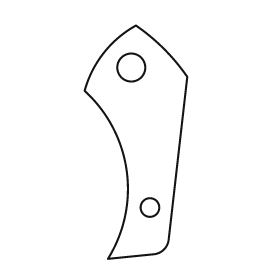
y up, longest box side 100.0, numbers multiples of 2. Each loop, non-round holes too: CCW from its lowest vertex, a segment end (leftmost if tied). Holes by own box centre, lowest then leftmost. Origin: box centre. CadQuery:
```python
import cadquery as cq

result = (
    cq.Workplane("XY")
    .moveTo(-12.0, -50.0)
    .lineTo(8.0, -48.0)
    .threePointArc((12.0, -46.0), (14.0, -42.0))
    .lineTo(22.0, 28.0)
    .threePointArc((12.0, 40.0), (0.0, 50.0))
    .threePointArc((-14.0, 38.0), (-22.0, 22.0))
    .threePointArc((-4.0, -12.0), (-12.0, -50.0))
    .close()
    .moveTo(6.0, -28.0)
    .circle(4.0)
    .moveTo(-2.0, 32.0)
    .circle(6.0)
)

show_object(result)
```